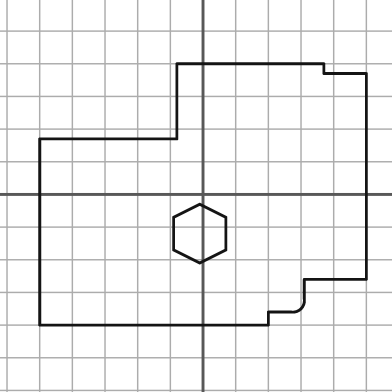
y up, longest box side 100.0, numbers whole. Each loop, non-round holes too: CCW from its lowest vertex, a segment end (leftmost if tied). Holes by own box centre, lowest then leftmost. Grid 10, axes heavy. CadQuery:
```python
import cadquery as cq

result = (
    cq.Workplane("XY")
    .moveTo(-50.0, -40.0)
    .lineTo(20.0, -40.0)
    .lineTo(20.0, -36.0)
    .lineTo(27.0, -36.0)
    .threePointArc((30.0, -35.0), (31.0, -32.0))
    .lineTo(31.0, -26.0)
    .lineTo(50.0, -26.0)
    .lineTo(50.0, 37.0)
    .lineTo(37.0, 37.0)
    .lineTo(37.0, 40.0)
    .lineTo(-8.0, 40.0)
    .lineTo(-8.0, 17.0)
    .lineTo(-50.0, 17.0)
    .close()
    .moveTo(-1.0, -21.0)
    .lineTo(7.0, -17.0)
    .lineTo(7.0, -7.0)
    .lineTo(-1.0, -3.0)
    .lineTo(-9.0, -7.0)
    .lineTo(-9.0, -17.0)
    .close()
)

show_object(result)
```